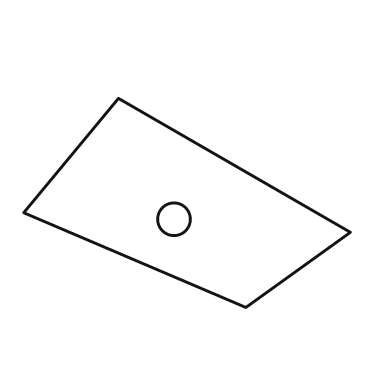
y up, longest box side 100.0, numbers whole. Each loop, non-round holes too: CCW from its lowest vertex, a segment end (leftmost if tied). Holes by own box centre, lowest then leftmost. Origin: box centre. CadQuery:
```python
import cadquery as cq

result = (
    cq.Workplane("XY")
    .moveTo(18.0, -32.0)
    .lineTo(50.0, -9.0)
    .lineTo(-21.0, 32.0)
    .lineTo(-50.0, -3.0)
    .close()
    .moveTo(-4.0, -5.0)
    .circle(5.0)
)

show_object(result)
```